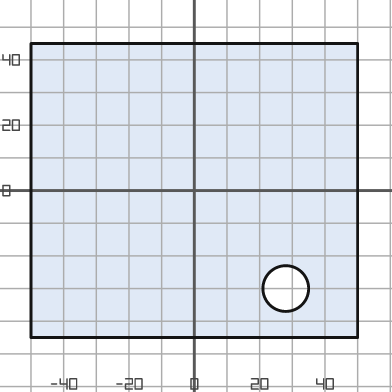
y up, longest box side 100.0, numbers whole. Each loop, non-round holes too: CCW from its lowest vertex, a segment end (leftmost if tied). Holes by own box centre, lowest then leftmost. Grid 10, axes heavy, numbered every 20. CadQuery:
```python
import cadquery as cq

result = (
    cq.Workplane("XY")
    .moveTo(-50.0, -45.0)
    .lineTo(50.0, -45.0)
    .lineTo(50.0, 45.0)
    .lineTo(-50.0, 45.0)
    .close()
    .moveTo(28.0, -30.0)
    .circle(7.0)
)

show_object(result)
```